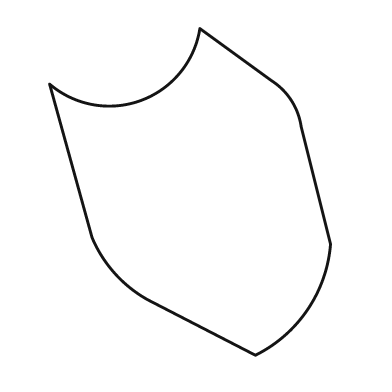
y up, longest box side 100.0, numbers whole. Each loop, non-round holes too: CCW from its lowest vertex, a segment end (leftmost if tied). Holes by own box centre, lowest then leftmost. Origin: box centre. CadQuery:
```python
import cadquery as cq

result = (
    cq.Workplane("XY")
    .moveTo(20.0, -50.0)
    .threePointArc((36.0, -36.0), (43.0, -16.0))
    .lineTo(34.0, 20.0)
    .threePointArc((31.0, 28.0), (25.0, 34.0))
    .lineTo(3.0, 50.0)
    .threePointArc((-15.0, 28.0), (-43.0, 33.0))
    .lineTo(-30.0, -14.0)
    .threePointArc((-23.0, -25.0), (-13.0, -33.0))
    .close()
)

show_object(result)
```